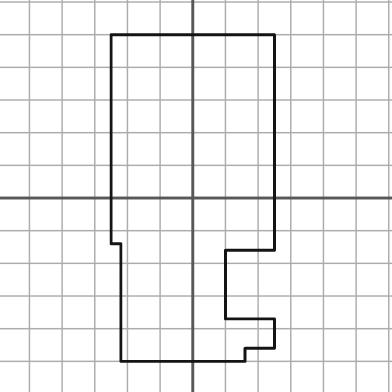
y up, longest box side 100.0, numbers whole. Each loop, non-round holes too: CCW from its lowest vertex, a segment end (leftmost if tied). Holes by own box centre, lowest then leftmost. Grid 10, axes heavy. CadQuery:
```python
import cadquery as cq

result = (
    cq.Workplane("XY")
    .moveTo(-22.0, -50.0)
    .lineTo(16.0, -50.0)
    .lineTo(16.0, -46.0)
    .lineTo(25.0, -46.0)
    .lineTo(25.0, -37.0)
    .lineTo(10.0, -37.0)
    .lineTo(10.0, -16.0)
    .lineTo(25.0, -16.0)
    .lineTo(25.0, 50.0)
    .lineTo(-25.0, 50.0)
    .lineTo(-25.0, -14.0)
    .lineTo(-22.0, -14.0)
    .close()
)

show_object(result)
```